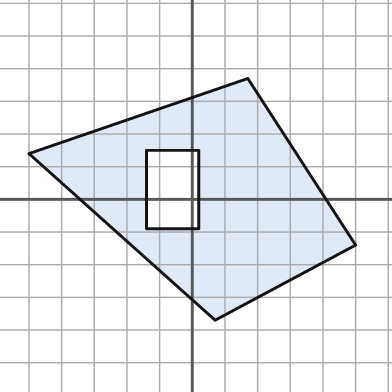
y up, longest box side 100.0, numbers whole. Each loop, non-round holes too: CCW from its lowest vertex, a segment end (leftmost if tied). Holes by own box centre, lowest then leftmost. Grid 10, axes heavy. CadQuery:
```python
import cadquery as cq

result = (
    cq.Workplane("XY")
    .moveTo(7.0, -37.0)
    .lineTo(50.0, -14.0)
    .lineTo(17.0, 37.0)
    .lineTo(-50.0, 14.0)
    .close()
    .moveTo(-14.0, -9.0)
    .lineTo(2.0, -9.0)
    .lineTo(2.0, 15.0)
    .lineTo(-14.0, 15.0)
    .close()
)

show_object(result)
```